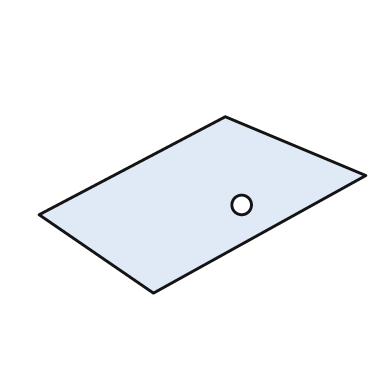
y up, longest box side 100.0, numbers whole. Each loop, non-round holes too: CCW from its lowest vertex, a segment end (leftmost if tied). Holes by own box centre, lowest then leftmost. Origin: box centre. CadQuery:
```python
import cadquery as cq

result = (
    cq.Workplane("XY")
    .moveTo(-15.0, -27.0)
    .lineTo(50.0, 9.0)
    .lineTo(7.0, 27.0)
    .lineTo(-50.0, -3.0)
    .close()
    .moveTo(12.0, 0.0)
    .circle(3.0)
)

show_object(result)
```